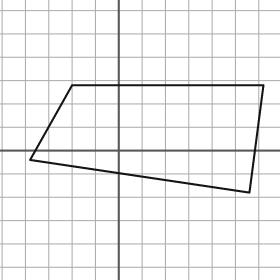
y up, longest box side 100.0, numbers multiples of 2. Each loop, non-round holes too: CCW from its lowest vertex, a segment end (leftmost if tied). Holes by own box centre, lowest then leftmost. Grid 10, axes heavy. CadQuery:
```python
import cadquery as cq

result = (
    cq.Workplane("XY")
    .moveTo(56.0, -18.0)
    .lineTo(62.0, 28.0)
    .lineTo(-20.0, 28.0)
    .lineTo(-38.0, -4.0)
    .close()
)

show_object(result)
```